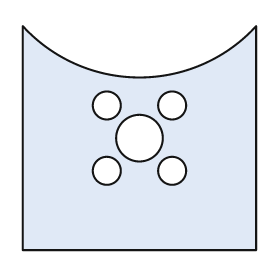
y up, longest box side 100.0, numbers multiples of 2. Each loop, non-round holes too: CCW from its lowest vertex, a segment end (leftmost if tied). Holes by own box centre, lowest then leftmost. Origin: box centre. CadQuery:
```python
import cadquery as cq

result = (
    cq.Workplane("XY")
    .moveTo(-50.0, -48.0)
    .lineTo(50.0, -48.0)
    .lineTo(50.0, 48.0)
    .threePointArc((0.0, 26.0), (-50.0, 48.0))
    .close()
    .moveTo(-14.0, -14.0)
    .circle(6.0)
    .moveTo(14.0, -14.0)
    .circle(6.0)
    .moveTo(0.0, 0.0)
    .circle(10.0)
    .moveTo(-14.0, 14.0)
    .circle(6.0)
    .moveTo(14.0, 14.0)
    .circle(6.0)
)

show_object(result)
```